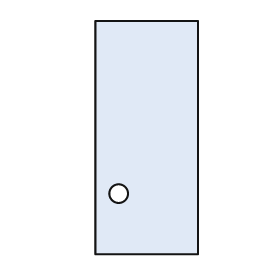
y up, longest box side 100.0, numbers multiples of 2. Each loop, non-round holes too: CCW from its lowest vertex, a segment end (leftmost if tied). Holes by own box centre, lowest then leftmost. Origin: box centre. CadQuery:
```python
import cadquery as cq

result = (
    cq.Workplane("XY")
    .moveTo(-22.0, -50.0)
    .lineTo(22.0, -50.0)
    .lineTo(22.0, 50.0)
    .lineTo(-22.0, 50.0)
    .close()
    .moveTo(-12.0, -24.0)
    .circle(4.0)
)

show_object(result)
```